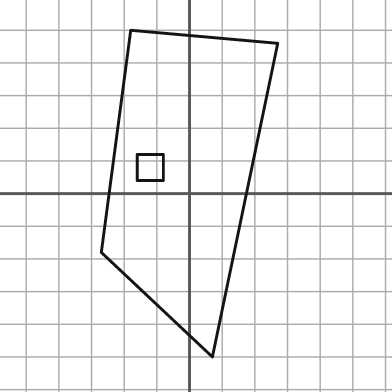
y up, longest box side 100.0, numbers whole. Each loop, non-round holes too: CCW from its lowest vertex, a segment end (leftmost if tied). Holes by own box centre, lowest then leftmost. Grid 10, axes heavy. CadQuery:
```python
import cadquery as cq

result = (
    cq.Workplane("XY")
    .moveTo(7.0, -50.0)
    .lineTo(27.0, 46.0)
    .lineTo(-18.0, 50.0)
    .lineTo(-27.0, -18.0)
    .close()
    .moveTo(-16.0, 4.0)
    .lineTo(-8.0, 4.0)
    .lineTo(-8.0, 12.0)
    .lineTo(-16.0, 12.0)
    .close()
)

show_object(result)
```